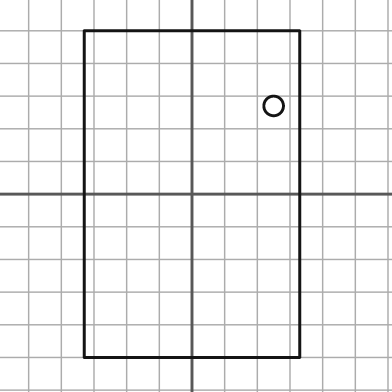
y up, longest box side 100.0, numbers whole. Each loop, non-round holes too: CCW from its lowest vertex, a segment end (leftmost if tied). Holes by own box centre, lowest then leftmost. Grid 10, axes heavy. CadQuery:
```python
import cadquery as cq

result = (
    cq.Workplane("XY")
    .moveTo(-33.0, -50.0)
    .lineTo(33.0, -50.0)
    .lineTo(33.0, 50.0)
    .lineTo(-33.0, 50.0)
    .close()
    .moveTo(25.0, 27.0)
    .circle(3.0)
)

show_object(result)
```